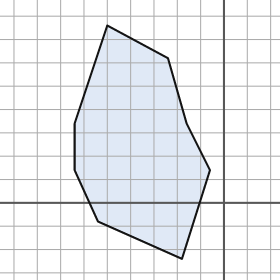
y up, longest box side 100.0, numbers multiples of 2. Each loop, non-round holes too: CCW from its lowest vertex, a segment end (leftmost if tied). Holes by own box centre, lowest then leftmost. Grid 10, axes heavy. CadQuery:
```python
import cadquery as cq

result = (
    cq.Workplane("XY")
    .moveTo(-18.0, -24.0)
    .lineTo(-6.0, 14.0)
    .lineTo(-16.0, 34.0)
    .lineTo(-24.0, 62.0)
    .lineTo(-50.0, 76.0)
    .lineTo(-64.0, 34.0)
    .lineTo(-64.0, 14.0)
    .lineTo(-54.0, -8.0)
    .close()
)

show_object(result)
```